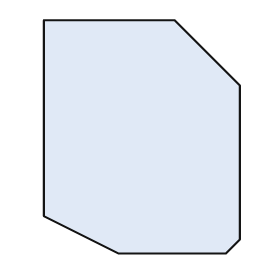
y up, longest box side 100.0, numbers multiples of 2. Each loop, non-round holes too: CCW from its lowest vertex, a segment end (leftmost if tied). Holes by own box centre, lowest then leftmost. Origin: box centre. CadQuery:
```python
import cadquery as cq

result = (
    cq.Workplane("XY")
    .moveTo(-10.0, -50.0)
    .lineTo(36.0, -50.0)
    .lineTo(42.0, -44.0)
    .lineTo(42.0, 22.0)
    .lineTo(14.0, 50.0)
    .lineTo(-42.0, 50.0)
    .lineTo(-42.0, -34.0)
    .close()
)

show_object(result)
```